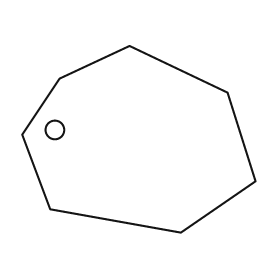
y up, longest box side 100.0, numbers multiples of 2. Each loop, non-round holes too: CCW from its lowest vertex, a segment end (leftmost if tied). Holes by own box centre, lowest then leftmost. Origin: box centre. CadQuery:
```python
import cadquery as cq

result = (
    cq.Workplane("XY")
    .moveTo(18.0, -40.0)
    .lineTo(50.0, -18.0)
    .lineTo(38.0, 20.0)
    .lineTo(-4.0, 40.0)
    .lineTo(-34.0, 26.0)
    .lineTo(-50.0, 2.0)
    .lineTo(-38.0, -30.0)
    .close()
    .moveTo(-36.0, 4.0)
    .circle(4.0)
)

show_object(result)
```